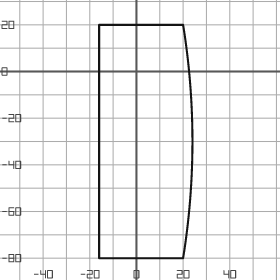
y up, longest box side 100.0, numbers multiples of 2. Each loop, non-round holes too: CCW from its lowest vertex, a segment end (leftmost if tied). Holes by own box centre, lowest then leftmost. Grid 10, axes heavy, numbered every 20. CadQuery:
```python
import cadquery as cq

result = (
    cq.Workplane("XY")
    .moveTo(-16.0, -80.0)
    .lineTo(20.0, -80.0)
    .threePointArc((24.0, -30.0), (20.0, 20.0))
    .lineTo(-16.0, 20.0)
    .close()
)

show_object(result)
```